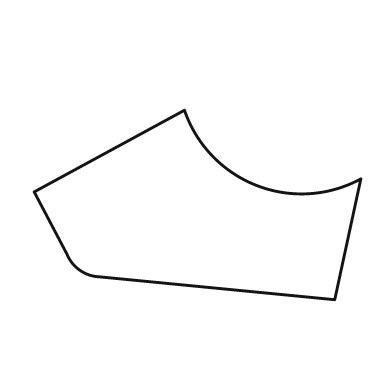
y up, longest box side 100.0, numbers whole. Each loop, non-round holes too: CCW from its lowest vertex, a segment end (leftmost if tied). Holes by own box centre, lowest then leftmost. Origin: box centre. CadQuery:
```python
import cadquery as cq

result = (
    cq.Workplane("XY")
    .moveTo(42.0, -29.0)
    .lineTo(50.0, 8.0)
    .threePointArc((18.0, 6.0), (-4.0, 29.0))
    .lineTo(-50.0, 4.0)
    .lineTo(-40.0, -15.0)
    .threePointArc((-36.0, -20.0), (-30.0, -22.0))
    .close()
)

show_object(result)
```